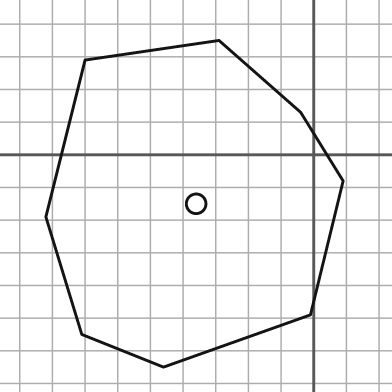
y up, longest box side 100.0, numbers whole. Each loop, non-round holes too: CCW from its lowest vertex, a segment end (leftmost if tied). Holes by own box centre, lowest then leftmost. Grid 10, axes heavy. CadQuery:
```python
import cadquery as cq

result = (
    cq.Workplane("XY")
    .moveTo(-46.0, -65.0)
    .lineTo(-1.0, -49.0)
    .lineTo(9.0, -8.0)
    .lineTo(-4.0, 13.0)
    .lineTo(-29.0, 35.0)
    .lineTo(-70.0, 29.0)
    .lineTo(-82.0, -19.0)
    .lineTo(-71.0, -55.0)
    .close()
    .moveTo(-36.0, -15.0)
    .circle(3.0)
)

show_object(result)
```